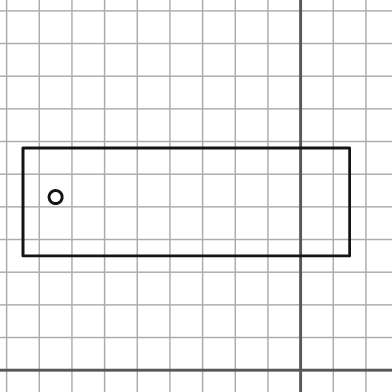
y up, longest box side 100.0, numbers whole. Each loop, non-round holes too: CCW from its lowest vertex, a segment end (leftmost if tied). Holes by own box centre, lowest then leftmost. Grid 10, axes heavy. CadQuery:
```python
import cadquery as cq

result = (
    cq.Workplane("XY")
    .moveTo(-85.0, 35.0)
    .lineTo(15.0, 35.0)
    .lineTo(15.0, 68.0)
    .lineTo(-85.0, 68.0)
    .close()
    .moveTo(-75.0, 53.0)
    .circle(2.0)
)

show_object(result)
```